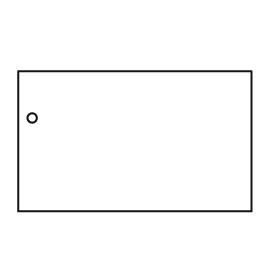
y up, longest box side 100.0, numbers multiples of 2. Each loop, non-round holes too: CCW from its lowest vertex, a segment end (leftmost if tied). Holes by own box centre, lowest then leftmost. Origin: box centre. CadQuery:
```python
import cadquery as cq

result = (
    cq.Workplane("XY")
    .moveTo(-50.0, -30.0)
    .lineTo(50.0, -30.0)
    .lineTo(50.0, 30.0)
    .lineTo(-50.0, 30.0)
    .close()
    .moveTo(-44.0, 10.0)
    .circle(2.0)
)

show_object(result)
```